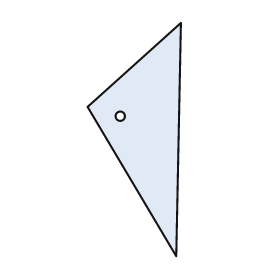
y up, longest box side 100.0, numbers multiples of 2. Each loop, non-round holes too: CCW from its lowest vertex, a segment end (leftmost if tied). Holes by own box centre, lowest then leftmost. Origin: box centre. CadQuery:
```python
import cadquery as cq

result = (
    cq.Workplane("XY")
    .moveTo(18.0, -50.0)
    .lineTo(20.0, 50.0)
    .lineTo(-20.0, 14.0)
    .close()
    .moveTo(-6.0, 10.0)
    .circle(2.0)
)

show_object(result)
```